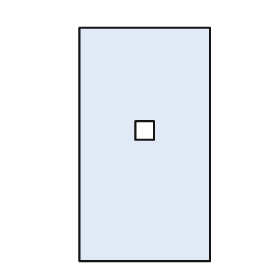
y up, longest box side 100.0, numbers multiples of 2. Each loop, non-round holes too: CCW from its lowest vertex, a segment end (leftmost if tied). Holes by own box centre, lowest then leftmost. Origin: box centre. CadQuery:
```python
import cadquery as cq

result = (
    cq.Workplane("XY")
    .moveTo(-28.0, -50.0)
    .lineTo(28.0, -50.0)
    .lineTo(28.0, 50.0)
    .lineTo(-28.0, 50.0)
    .close()
    .moveTo(-4.0, 2.0)
    .lineTo(4.0, 2.0)
    .lineTo(4.0, 10.0)
    .lineTo(-4.0, 10.0)
    .close()
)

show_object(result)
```